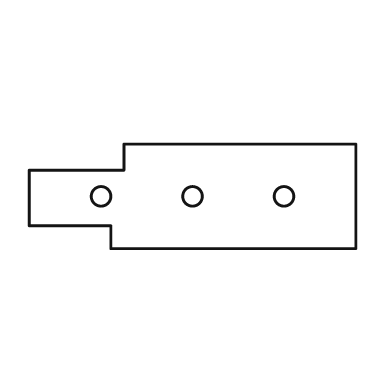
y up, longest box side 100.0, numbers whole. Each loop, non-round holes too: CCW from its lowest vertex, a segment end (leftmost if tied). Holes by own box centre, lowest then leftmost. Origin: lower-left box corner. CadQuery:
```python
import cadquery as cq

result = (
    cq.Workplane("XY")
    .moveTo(25.0, 0.0)
    .lineTo(100.0, 0.0)
    .lineTo(100.0, 32.0)
    .lineTo(29.0, 32.0)
    .lineTo(29.0, 24.0)
    .lineTo(0.0, 24.0)
    .lineTo(0.0, 7.0)
    .lineTo(25.0, 7.0)
    .close()
    .moveTo(22.0, 16.0)
    .circle(3.0)
    .moveTo(50.0, 16.0)
    .circle(3.0)
    .moveTo(78.0, 16.0)
    .circle(3.0)
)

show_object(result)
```